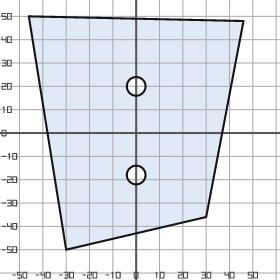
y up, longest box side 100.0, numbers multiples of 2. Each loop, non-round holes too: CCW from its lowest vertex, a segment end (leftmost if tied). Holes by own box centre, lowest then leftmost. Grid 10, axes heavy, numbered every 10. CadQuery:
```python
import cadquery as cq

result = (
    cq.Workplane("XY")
    .moveTo(-30.0, -50.0)
    .lineTo(30.0, -36.0)
    .lineTo(46.0, 48.0)
    .lineTo(-46.0, 50.0)
    .close()
    .moveTo(0.0, -18.0)
    .circle(4.0)
    .moveTo(0.0, 20.0)
    .circle(4.0)
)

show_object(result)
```